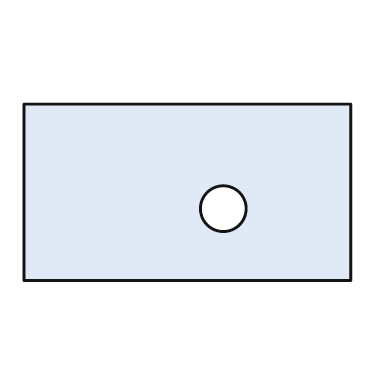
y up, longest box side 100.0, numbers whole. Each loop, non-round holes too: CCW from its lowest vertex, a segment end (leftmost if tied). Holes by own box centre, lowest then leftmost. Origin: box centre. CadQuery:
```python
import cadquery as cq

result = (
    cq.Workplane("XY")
    .moveTo(-50.0, -27.0)
    .lineTo(50.0, -27.0)
    .lineTo(50.0, 27.0)
    .lineTo(-50.0, 27.0)
    .close()
    .moveTo(11.0, -5.0)
    .circle(7.0)
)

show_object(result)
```